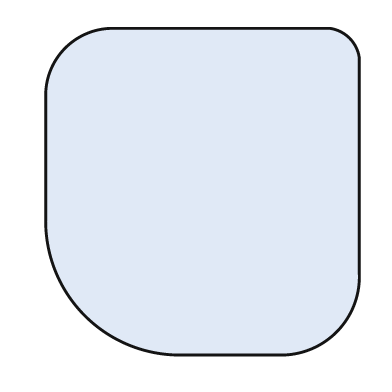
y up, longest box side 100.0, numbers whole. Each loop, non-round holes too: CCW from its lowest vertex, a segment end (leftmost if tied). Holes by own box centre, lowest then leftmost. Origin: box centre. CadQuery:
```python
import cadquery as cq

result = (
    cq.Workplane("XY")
    .moveTo(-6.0, -50.0)
    .lineTo(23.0, -50.0)
    .threePointArc((41.0, -43.0), (48.0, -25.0))
    .lineTo(48.0, 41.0)
    .threePointArc((45.0, 47.0), (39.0, 50.0))
    .lineTo(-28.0, 50.0)
    .threePointArc((-42.0, 44.0), (-48.0, 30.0))
    .lineTo(-48.0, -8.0)
    .threePointArc((-36.0, -38.0), (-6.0, -50.0))
    .close()
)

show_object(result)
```